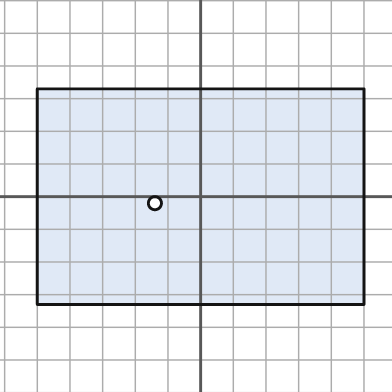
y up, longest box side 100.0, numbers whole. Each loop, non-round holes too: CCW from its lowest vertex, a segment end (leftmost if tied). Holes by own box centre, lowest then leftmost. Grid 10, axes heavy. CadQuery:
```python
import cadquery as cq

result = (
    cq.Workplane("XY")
    .moveTo(-50.0, -33.0)
    .lineTo(50.0, -33.0)
    .lineTo(50.0, 33.0)
    .lineTo(-50.0, 33.0)
    .close()
    .moveTo(-14.0, -2.0)
    .circle(2.0)
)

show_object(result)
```